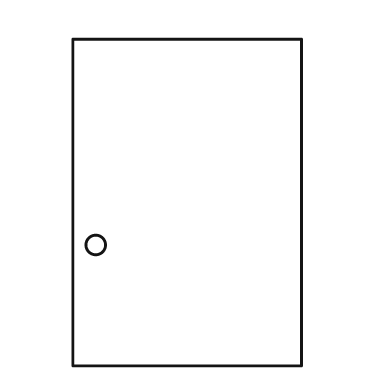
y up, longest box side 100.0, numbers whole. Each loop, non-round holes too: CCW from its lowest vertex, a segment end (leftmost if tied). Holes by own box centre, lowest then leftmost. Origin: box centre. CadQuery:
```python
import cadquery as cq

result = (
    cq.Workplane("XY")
    .moveTo(-35.0, -50.0)
    .lineTo(35.0, -50.0)
    .lineTo(35.0, 50.0)
    .lineTo(-35.0, 50.0)
    .close()
    .moveTo(-28.0, -13.0)
    .circle(3.0)
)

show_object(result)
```